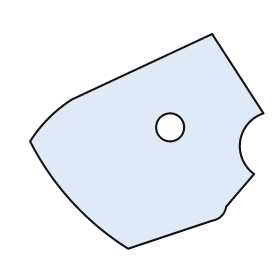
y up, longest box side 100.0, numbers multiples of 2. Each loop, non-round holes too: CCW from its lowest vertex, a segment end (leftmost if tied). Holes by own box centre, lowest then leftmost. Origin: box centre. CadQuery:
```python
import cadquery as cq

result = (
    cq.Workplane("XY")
    .moveTo(-8.0, -46.0)
    .lineTo(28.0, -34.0)
    .threePointArc((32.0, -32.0), (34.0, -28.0))
    .lineTo(46.0, -14.0)
    .threePointArc((40.0, 0.0), (50.0, 12.0))
    .lineTo(28.0, 46.0)
    .lineTo(-32.0, 18.0)
    .threePointArc((-42.0, 10.0), (-50.0, 0.0))
    .threePointArc((-32.0, -26.0), (-8.0, -46.0))
    .close()
    .moveTo(10.0, 6.0)
    .circle(6.0)
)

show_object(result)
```